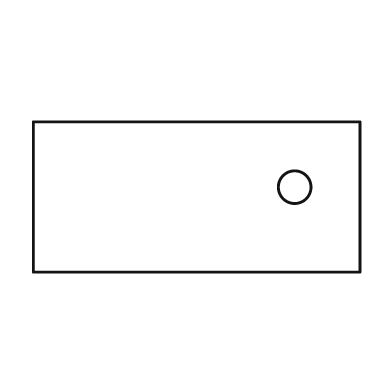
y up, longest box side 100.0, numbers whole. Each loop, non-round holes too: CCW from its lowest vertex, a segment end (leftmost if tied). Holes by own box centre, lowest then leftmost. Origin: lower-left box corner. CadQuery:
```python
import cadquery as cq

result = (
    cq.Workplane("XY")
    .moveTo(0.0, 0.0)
    .lineTo(100.0, 0.0)
    .lineTo(100.0, 46.0)
    .lineTo(0.0, 46.0)
    .close()
    .moveTo(80.0, 26.0)
    .circle(5.0)
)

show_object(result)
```